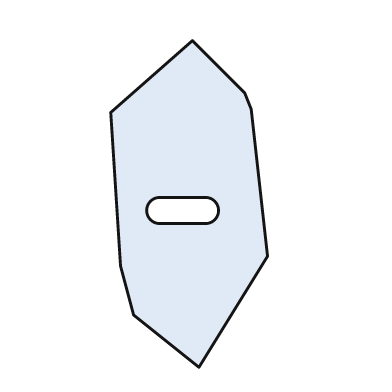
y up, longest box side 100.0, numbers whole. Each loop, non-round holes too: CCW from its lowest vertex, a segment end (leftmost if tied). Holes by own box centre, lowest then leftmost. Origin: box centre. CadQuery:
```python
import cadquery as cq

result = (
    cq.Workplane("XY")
    .moveTo(3.0, -50.0)
    .lineTo(24.0, -16.0)
    .lineTo(19.0, 29.0)
    .lineTo(17.0, 34.0)
    .lineTo(1.0, 50.0)
    .lineTo(-24.0, 28.0)
    .lineTo(-21.0, -19.0)
    .lineTo(-17.0, -34.0)
    .close()
    .moveTo(-9.0, -6.0)
    .lineTo(5.0, -6.0)
    .threePointArc((9.0, -2.0), (5.0, 2.0))
    .lineTo(-9.0, 2.0)
    .threePointArc((-13.0, -2.0), (-9.0, -6.0))
    .close()
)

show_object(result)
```